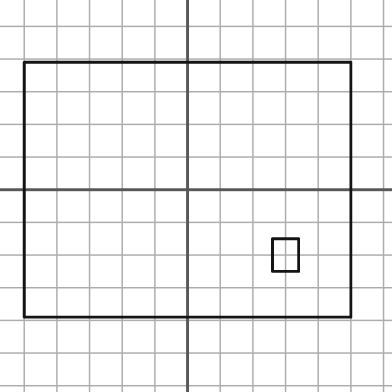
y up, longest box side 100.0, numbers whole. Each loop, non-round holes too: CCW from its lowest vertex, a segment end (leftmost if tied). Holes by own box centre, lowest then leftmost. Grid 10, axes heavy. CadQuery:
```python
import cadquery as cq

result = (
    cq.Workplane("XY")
    .moveTo(-50.0, -39.0)
    .lineTo(50.0, -39.0)
    .lineTo(50.0, 39.0)
    .lineTo(-50.0, 39.0)
    .close()
    .moveTo(26.0, -25.0)
    .lineTo(34.0, -25.0)
    .lineTo(34.0, -15.0)
    .lineTo(26.0, -15.0)
    .close()
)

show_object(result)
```